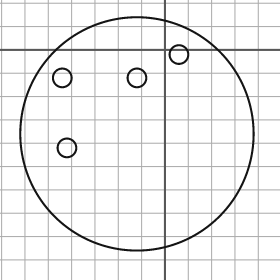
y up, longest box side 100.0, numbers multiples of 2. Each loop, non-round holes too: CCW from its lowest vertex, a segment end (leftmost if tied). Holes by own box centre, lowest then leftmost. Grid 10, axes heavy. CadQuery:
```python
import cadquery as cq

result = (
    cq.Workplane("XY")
    .moveTo(-12.0, -36.0)
    .circle(50.0)
    .moveTo(-42.0, -42.0)
    .circle(4.0)
    .moveTo(-44.0, -12.0)
    .circle(4.0)
    .moveTo(-12.0, -12.0)
    .circle(4.0)
    .moveTo(6.0, -2.0)
    .circle(4.0)
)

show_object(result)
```